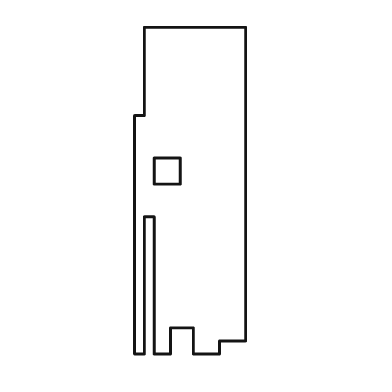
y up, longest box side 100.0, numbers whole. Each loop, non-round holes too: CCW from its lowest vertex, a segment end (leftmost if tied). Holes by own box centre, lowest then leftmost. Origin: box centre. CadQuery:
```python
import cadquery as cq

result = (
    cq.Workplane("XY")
    .moveTo(-17.0, -50.0)
    .lineTo(-14.0, -50.0)
    .lineTo(-14.0, -8.0)
    .lineTo(-11.0, -8.0)
    .lineTo(-11.0, -50.0)
    .lineTo(-6.0, -50.0)
    .lineTo(-6.0, -42.0)
    .lineTo(1.0, -42.0)
    .lineTo(1.0, -50.0)
    .lineTo(9.0, -50.0)
    .lineTo(9.0, -46.0)
    .lineTo(17.0, -46.0)
    .lineTo(17.0, 50.0)
    .lineTo(-14.0, 50.0)
    .lineTo(-14.0, 23.0)
    .lineTo(-17.0, 23.0)
    .close()
    .moveTo(-11.0, 2.0)
    .lineTo(-3.0, 2.0)
    .lineTo(-3.0, 10.0)
    .lineTo(-11.0, 10.0)
    .close()
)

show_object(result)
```